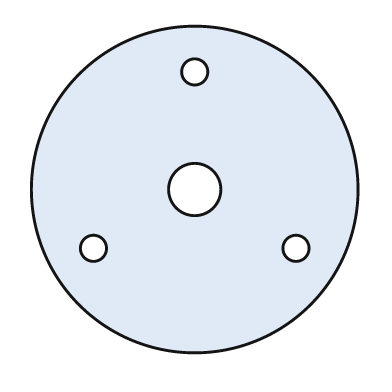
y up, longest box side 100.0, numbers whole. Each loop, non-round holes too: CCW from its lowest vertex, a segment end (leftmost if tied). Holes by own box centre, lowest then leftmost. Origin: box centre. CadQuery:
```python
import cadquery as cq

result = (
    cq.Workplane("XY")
    .moveTo(0.0, 0.0)
    .circle(50.0)
    .moveTo(-31.0, -18.0)
    .circle(4.0)
    .moveTo(31.0, -18.0)
    .circle(4.0)
    .moveTo(0.0, 0.0)
    .circle(8.0)
    .moveTo(0.0, 36.0)
    .circle(4.0)
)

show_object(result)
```